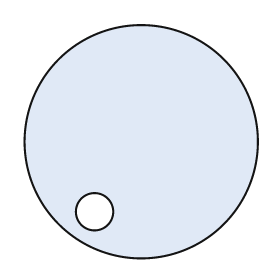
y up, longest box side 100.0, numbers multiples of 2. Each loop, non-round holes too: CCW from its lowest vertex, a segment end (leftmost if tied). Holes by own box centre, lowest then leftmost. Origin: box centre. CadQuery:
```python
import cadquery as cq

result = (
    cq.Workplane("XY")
    .moveTo(0.0, 0.0)
    .circle(50.0)
    .moveTo(-20.0, -30.0)
    .circle(8.0)
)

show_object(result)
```